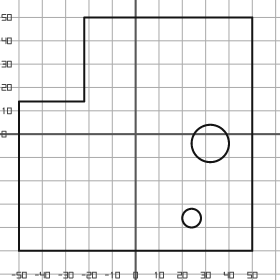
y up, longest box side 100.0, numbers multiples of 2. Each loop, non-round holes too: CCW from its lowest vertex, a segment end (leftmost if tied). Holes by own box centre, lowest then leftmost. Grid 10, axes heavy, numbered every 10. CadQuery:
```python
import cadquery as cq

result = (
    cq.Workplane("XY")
    .moveTo(-50.0, -50.0)
    .lineTo(50.0, -50.0)
    .lineTo(50.0, 50.0)
    .lineTo(-22.0, 50.0)
    .lineTo(-22.0, 14.0)
    .lineTo(-50.0, 14.0)
    .close()
    .moveTo(24.0, -36.0)
    .circle(4.0)
    .moveTo(32.0, -4.0)
    .circle(8.0)
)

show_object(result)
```